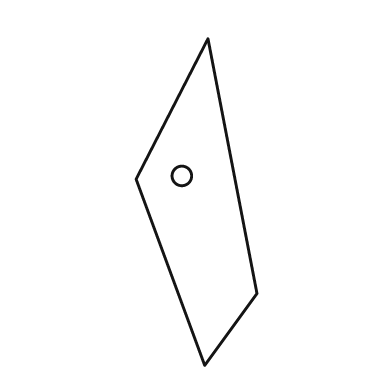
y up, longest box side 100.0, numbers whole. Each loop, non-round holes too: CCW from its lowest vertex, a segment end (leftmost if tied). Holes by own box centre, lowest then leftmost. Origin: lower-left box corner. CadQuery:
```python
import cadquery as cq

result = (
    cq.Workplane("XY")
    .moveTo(21.0, 0.0)
    .lineTo(37.0, 22.0)
    .lineTo(22.0, 100.0)
    .lineTo(0.0, 57.0)
    .close()
    .moveTo(14.0, 58.0)
    .circle(3.0)
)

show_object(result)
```